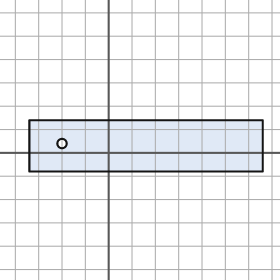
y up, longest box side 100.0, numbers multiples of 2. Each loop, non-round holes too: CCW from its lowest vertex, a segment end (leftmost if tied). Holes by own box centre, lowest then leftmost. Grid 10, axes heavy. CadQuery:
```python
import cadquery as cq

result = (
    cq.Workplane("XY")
    .moveTo(-34.0, -8.0)
    .lineTo(66.0, -8.0)
    .lineTo(66.0, 14.0)
    .lineTo(-34.0, 14.0)
    .close()
    .moveTo(-20.0, 4.0)
    .circle(2.0)
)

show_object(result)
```